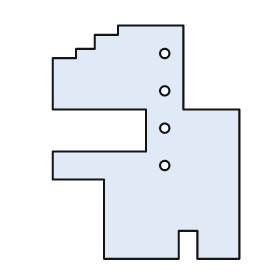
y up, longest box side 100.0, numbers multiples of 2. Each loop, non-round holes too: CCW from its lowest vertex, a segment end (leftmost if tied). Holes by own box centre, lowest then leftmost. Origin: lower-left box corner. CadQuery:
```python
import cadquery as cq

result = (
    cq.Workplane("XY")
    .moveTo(22.0, 0.0)
    .lineTo(54.0, 0.0)
    .lineTo(54.0, 12.0)
    .lineTo(62.0, 12.0)
    .lineTo(62.0, 0.0)
    .lineTo(80.0, 0.0)
    .lineTo(80.0, 64.0)
    .lineTo(56.0, 64.0)
    .lineTo(56.0, 100.0)
    .lineTo(28.0, 100.0)
    .lineTo(28.0, 96.0)
    .lineTo(18.0, 96.0)
    .lineTo(18.0, 90.0)
    .lineTo(10.0, 90.0)
    .lineTo(10.0, 86.0)
    .lineTo(0.0, 86.0)
    .lineTo(0.0, 64.0)
    .lineTo(40.0, 64.0)
    .lineTo(40.0, 46.0)
    .lineTo(0.0, 46.0)
    .lineTo(0.0, 34.0)
    .lineTo(22.0, 34.0)
    .close()
    .moveTo(48.0, 40.0)
    .circle(2.0)
    .moveTo(48.0, 56.0)
    .circle(2.0)
    .moveTo(48.0, 72.0)
    .circle(2.0)
    .moveTo(48.0, 88.0)
    .circle(2.0)
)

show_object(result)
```